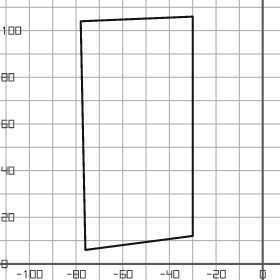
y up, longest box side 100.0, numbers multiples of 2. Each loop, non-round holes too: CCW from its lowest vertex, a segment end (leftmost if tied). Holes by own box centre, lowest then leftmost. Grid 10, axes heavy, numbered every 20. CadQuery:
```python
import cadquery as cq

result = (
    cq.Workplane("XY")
    .moveTo(-76.0, 6.0)
    .lineTo(-30.0, 12.0)
    .lineTo(-30.0, 106.0)
    .lineTo(-78.0, 104.0)
    .close()
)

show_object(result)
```